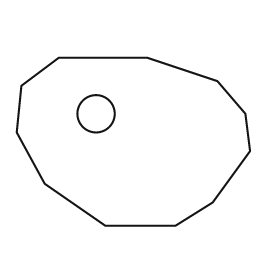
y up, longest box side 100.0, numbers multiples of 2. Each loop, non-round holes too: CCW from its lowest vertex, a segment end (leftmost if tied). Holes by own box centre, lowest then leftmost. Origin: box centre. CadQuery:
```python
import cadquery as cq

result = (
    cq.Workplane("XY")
    .moveTo(-12.0, -36.0)
    .lineTo(18.0, -36.0)
    .lineTo(34.0, -26.0)
    .lineTo(50.0, -4.0)
    .lineTo(48.0, 12.0)
    .lineTo(36.0, 26.0)
    .lineTo(6.0, 36.0)
    .lineTo(-32.0, 36.0)
    .lineTo(-48.0, 24.0)
    .lineTo(-50.0, 4.0)
    .lineTo(-38.0, -18.0)
    .close()
    .moveTo(-16.0, 12.0)
    .circle(8.0)
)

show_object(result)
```